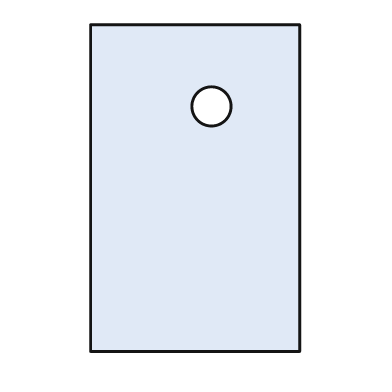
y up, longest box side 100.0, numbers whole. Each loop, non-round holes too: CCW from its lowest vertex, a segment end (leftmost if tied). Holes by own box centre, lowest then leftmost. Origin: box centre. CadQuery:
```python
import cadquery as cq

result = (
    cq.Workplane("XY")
    .moveTo(-32.0, -50.0)
    .lineTo(32.0, -50.0)
    .lineTo(32.0, 50.0)
    .lineTo(-32.0, 50.0)
    .close()
    .moveTo(5.0, 25.0)
    .circle(6.0)
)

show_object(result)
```